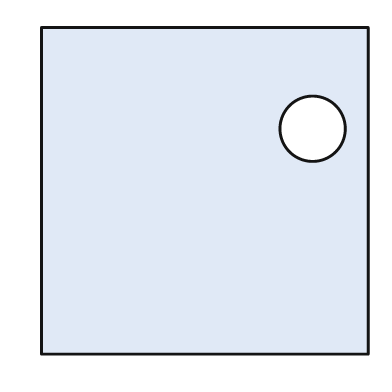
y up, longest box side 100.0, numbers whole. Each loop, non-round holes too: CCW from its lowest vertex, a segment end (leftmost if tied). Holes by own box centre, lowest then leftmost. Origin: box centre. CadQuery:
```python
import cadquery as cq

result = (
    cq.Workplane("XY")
    .moveTo(-50.0, -50.0)
    .lineTo(50.0, -50.0)
    .lineTo(50.0, 50.0)
    .lineTo(-50.0, 50.0)
    .close()
    .moveTo(33.0, 19.0)
    .circle(10.0)
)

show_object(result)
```